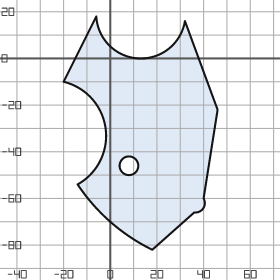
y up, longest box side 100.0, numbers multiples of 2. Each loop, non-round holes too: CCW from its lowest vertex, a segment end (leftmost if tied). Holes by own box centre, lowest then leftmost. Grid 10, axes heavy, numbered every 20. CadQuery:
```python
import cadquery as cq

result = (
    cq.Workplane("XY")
    .moveTo(18.0, -82.0)
    .lineTo(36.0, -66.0)
    .threePointArc((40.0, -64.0), (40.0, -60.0))
    .lineTo(46.0, -22.0)
    .lineTo(32.0, 16.0)
    .threePointArc((12.0, 0.0), (-6.0, 18.0))
    .lineTo(-20.0, -10.0)
    .threePointArc((-2.0, -30.0), (-14.0, -54.0))
    .threePointArc((0.0, -70.0), (18.0, -82.0))
    .close()
    .moveTo(8.0, -46.0)
    .circle(4.0)
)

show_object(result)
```